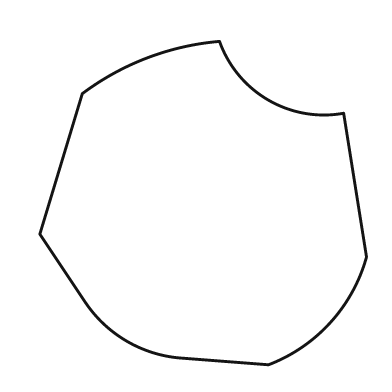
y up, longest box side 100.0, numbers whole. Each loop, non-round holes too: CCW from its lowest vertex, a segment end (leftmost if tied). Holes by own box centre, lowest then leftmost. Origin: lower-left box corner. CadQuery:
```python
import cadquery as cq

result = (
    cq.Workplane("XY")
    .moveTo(70.0, 0.0)
    .threePointArc((89.0, 13.0), (100.0, 33.0))
    .lineTo(93.0, 77.0)
    .threePointArc((70.0, 81.0), (55.0, 99.0))
    .threePointArc((33.0, 94.0), (13.0, 83.0))
    .lineTo(0.0, 40.0)
    .lineTo(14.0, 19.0)
    .threePointArc((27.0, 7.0), (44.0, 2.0))
    .close()
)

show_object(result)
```